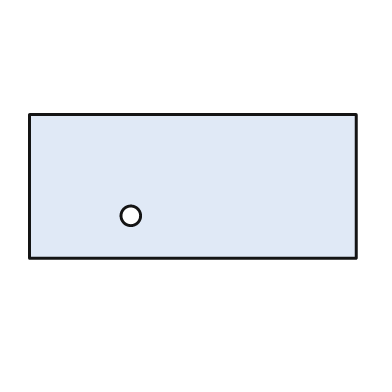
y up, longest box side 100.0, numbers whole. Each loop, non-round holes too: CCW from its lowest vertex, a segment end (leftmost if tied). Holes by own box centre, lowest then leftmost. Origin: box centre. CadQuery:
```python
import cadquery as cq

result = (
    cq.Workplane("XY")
    .moveTo(-50.0, -22.0)
    .lineTo(50.0, -22.0)
    .lineTo(50.0, 22.0)
    .lineTo(-50.0, 22.0)
    .close()
    .moveTo(-19.0, -9.0)
    .circle(3.0)
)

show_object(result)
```